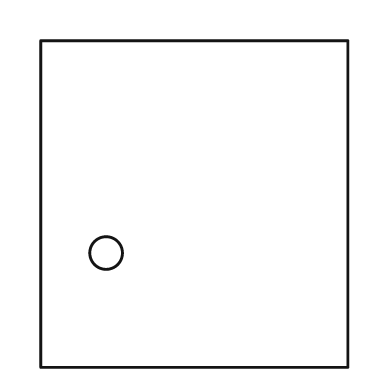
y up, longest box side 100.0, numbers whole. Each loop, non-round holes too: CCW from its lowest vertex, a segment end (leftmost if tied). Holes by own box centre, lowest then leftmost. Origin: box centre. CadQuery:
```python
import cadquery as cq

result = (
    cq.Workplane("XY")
    .moveTo(-47.0, -50.0)
    .lineTo(47.0, -50.0)
    .lineTo(47.0, 50.0)
    .lineTo(-47.0, 50.0)
    .close()
    .moveTo(-27.0, -15.0)
    .circle(5.0)
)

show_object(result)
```